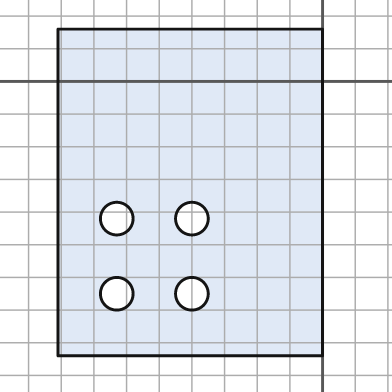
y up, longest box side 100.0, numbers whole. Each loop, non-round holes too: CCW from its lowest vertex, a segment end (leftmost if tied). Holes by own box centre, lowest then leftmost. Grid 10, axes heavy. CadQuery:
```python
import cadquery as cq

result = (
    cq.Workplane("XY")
    .moveTo(-81.0, -84.0)
    .lineTo(0.0, -84.0)
    .lineTo(0.0, 16.0)
    .lineTo(-81.0, 16.0)
    .close()
    .moveTo(-63.0, -65.0)
    .circle(5.0)
    .moveTo(-40.0, -65.0)
    .circle(5.0)
    .moveTo(-63.0, -42.0)
    .circle(5.0)
    .moveTo(-40.0, -42.0)
    .circle(5.0)
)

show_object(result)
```